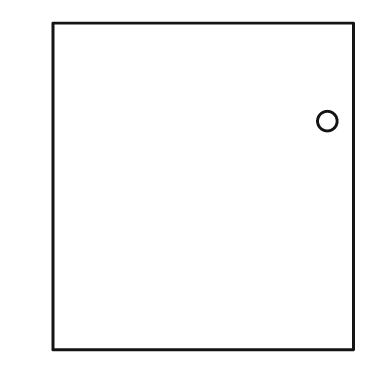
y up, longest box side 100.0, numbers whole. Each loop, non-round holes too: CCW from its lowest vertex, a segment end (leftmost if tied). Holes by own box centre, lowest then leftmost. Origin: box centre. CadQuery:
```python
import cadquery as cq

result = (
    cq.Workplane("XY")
    .moveTo(-46.0, -50.0)
    .lineTo(46.0, -50.0)
    .lineTo(46.0, 50.0)
    .lineTo(-46.0, 50.0)
    .close()
    .moveTo(38.0, 20.0)
    .circle(3.0)
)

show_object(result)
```